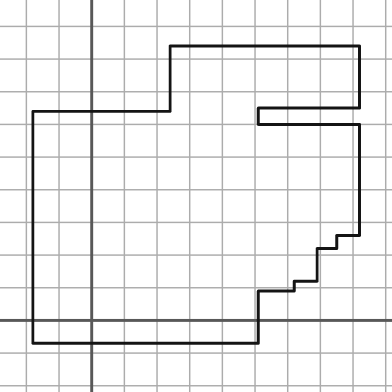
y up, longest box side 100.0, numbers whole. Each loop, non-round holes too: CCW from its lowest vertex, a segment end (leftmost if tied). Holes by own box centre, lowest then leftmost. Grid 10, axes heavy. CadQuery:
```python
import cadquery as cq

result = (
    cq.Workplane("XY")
    .moveTo(-18.0, -7.0)
    .lineTo(51.0, -7.0)
    .lineTo(51.0, 9.0)
    .lineTo(62.0, 9.0)
    .lineTo(62.0, 12.0)
    .lineTo(69.0, 12.0)
    .lineTo(69.0, 22.0)
    .lineTo(75.0, 22.0)
    .lineTo(75.0, 26.0)
    .lineTo(82.0, 26.0)
    .lineTo(82.0, 60.0)
    .lineTo(51.0, 60.0)
    .lineTo(51.0, 65.0)
    .lineTo(82.0, 65.0)
    .lineTo(82.0, 84.0)
    .lineTo(24.0, 84.0)
    .lineTo(24.0, 64.0)
    .lineTo(-18.0, 64.0)
    .close()
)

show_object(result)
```